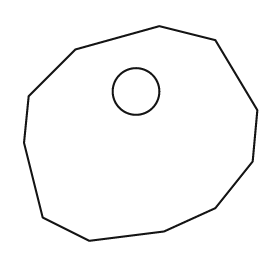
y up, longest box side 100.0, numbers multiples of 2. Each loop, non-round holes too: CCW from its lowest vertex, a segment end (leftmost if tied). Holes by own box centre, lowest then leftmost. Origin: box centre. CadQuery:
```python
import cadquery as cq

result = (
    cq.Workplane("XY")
    .moveTo(-22.0, -46.0)
    .lineTo(10.0, -42.0)
    .lineTo(32.0, -32.0)
    .lineTo(48.0, -12.0)
    .lineTo(50.0, 10.0)
    .lineTo(32.0, 40.0)
    .lineTo(8.0, 46.0)
    .lineTo(-28.0, 36.0)
    .lineTo(-48.0, 16.0)
    .lineTo(-50.0, -4.0)
    .lineTo(-42.0, -36.0)
    .close()
    .moveTo(-2.0, 18.0)
    .circle(10.0)
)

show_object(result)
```